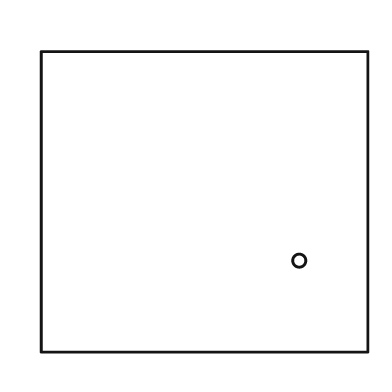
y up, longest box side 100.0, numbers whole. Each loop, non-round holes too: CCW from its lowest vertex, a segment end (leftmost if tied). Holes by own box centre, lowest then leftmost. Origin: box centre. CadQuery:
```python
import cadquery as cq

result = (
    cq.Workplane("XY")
    .moveTo(-50.0, -46.0)
    .lineTo(50.0, -46.0)
    .lineTo(50.0, 46.0)
    .lineTo(-50.0, 46.0)
    .close()
    .moveTo(29.0, -18.0)
    .circle(2.0)
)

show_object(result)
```